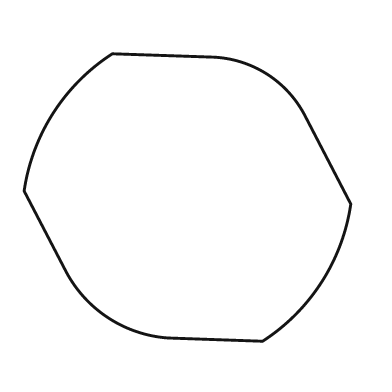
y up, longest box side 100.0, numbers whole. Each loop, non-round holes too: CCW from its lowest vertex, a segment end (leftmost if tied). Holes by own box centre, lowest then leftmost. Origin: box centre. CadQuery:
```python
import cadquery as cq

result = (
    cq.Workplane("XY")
    .moveTo(23.0, -44.0)
    .threePointArc((41.0, -26.0), (50.0, -2.0))
    .lineTo(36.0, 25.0)
    .threePointArc((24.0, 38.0), (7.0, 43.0))
    .lineTo(-23.0, 44.0)
    .threePointArc((-41.0, 26.0), (-50.0, 2.0))
    .lineTo(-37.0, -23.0)
    .threePointArc((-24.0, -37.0), (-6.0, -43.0))
    .close()
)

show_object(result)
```